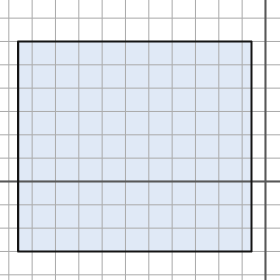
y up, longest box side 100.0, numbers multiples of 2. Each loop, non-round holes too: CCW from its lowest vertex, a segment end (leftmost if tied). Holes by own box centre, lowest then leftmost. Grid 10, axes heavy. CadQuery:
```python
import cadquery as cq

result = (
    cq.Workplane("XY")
    .moveTo(-106.0, -30.0)
    .lineTo(-6.0, -30.0)
    .lineTo(-6.0, 60.0)
    .lineTo(-106.0, 60.0)
    .close()
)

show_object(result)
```